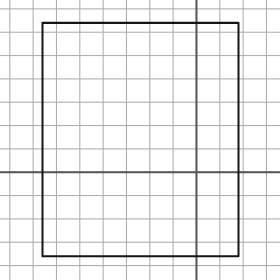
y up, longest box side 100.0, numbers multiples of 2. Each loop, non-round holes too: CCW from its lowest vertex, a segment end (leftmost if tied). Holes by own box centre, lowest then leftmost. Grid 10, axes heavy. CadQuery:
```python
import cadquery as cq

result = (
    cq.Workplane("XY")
    .moveTo(-66.0, -36.0)
    .lineTo(18.0, -36.0)
    .lineTo(18.0, 64.0)
    .lineTo(-66.0, 64.0)
    .close()
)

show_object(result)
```